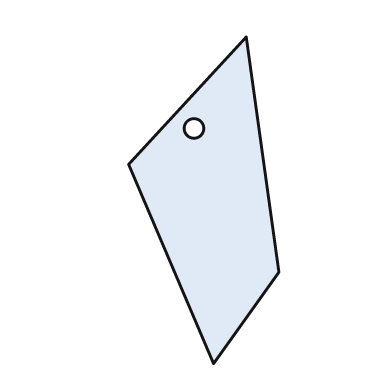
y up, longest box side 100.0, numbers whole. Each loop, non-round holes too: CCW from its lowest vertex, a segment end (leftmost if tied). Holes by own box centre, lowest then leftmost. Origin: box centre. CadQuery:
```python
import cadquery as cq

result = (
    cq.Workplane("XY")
    .moveTo(3.0, -50.0)
    .lineTo(23.0, -22.0)
    .lineTo(13.0, 50.0)
    .lineTo(-23.0, 11.0)
    .close()
    .moveTo(-3.0, 22.0)
    .circle(3.0)
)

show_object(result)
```